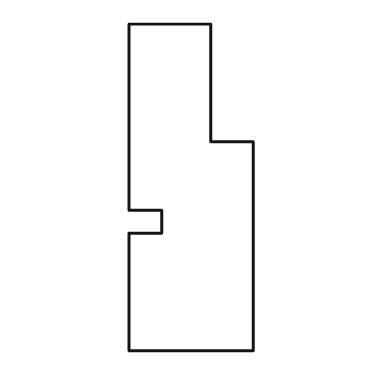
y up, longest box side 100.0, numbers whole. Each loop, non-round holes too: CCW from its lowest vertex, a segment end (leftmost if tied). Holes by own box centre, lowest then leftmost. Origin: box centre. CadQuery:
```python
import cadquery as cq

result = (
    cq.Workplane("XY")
    .moveTo(-19.0, -50.0)
    .lineTo(19.0, -50.0)
    .lineTo(19.0, 14.0)
    .lineTo(6.0, 14.0)
    .lineTo(6.0, 50.0)
    .lineTo(-19.0, 50.0)
    .lineTo(-19.0, -7.0)
    .lineTo(-9.0, -7.0)
    .lineTo(-9.0, -14.0)
    .lineTo(-19.0, -14.0)
    .close()
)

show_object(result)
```